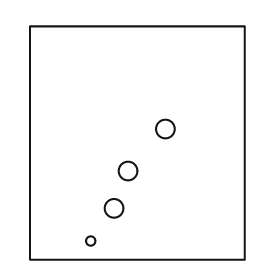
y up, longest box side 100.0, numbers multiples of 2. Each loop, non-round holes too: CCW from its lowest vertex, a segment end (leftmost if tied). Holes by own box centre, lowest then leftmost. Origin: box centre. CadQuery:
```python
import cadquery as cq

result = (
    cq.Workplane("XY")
    .moveTo(-46.0, -50.0)
    .lineTo(46.0, -50.0)
    .lineTo(46.0, 50.0)
    .lineTo(-46.0, 50.0)
    .close()
    .moveTo(-20.0, -42.0)
    .circle(2.0)
    .moveTo(-10.0, -28.0)
    .circle(4.0)
    .moveTo(-4.0, -12.0)
    .circle(4.0)
    .moveTo(12.0, 6.0)
    .circle(4.0)
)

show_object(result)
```